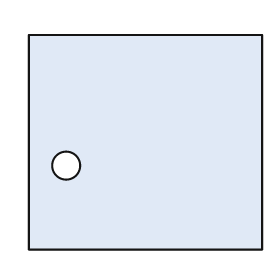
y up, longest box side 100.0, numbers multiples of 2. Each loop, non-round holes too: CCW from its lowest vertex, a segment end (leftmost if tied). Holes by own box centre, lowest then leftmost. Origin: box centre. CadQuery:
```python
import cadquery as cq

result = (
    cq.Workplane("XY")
    .moveTo(-50.0, -46.0)
    .lineTo(50.0, -46.0)
    .lineTo(50.0, 46.0)
    .lineTo(-50.0, 46.0)
    .close()
    .moveTo(-34.0, -10.0)
    .circle(6.0)
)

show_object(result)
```